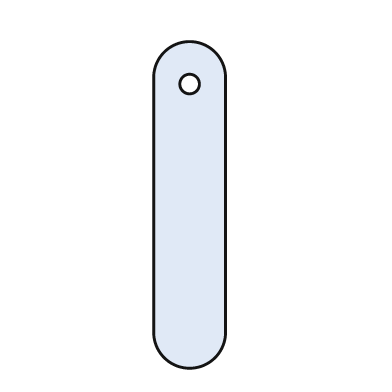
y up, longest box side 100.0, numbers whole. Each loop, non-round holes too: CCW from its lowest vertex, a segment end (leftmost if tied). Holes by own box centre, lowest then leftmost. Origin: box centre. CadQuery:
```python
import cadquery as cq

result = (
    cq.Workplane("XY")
    .moveTo(-11.0, -39.0)
    .threePointArc((0.0, -50.0), (11.0, -39.0))
    .lineTo(11.0, 39.0)
    .threePointArc((0.0, 50.0), (-11.0, 39.0))
    .close()
    .moveTo(0.0, 37.0)
    .circle(3.0)
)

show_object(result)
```